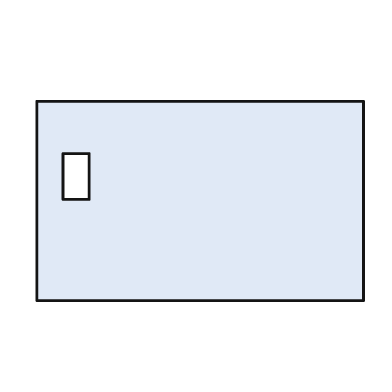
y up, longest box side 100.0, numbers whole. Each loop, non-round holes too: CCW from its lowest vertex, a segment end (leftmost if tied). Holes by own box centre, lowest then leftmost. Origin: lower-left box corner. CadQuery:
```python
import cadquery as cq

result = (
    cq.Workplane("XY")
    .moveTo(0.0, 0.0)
    .lineTo(100.0, 0.0)
    .lineTo(100.0, 61.0)
    .lineTo(0.0, 61.0)
    .close()
    .moveTo(8.0, 31.0)
    .lineTo(16.0, 31.0)
    .lineTo(16.0, 45.0)
    .lineTo(8.0, 45.0)
    .close()
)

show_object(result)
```